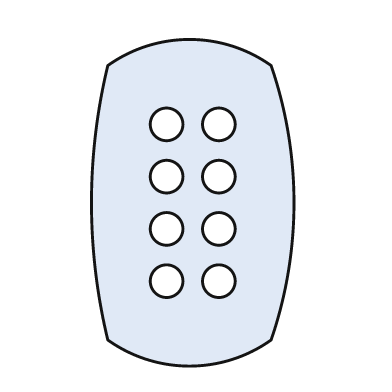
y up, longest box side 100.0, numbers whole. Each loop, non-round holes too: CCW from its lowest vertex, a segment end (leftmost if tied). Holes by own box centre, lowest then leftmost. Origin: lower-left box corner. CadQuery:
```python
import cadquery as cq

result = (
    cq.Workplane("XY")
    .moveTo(5.0, 8.0)
    .threePointArc((30.0, 0.0), (55.0, 8.0))
    .threePointArc((62.0, 50.0), (55.0, 92.0))
    .threePointArc((30.0, 100.0), (5.0, 92.0))
    .threePointArc((0.0, 50.0), (5.0, 8.0))
    .close()
    .moveTo(23.0, 26.0)
    .circle(5.0)
    .moveTo(39.0, 26.0)
    .circle(5.0)
    .moveTo(23.0, 42.0)
    .circle(5.0)
    .moveTo(39.0, 42.0)
    .circle(5.0)
    .moveTo(23.0, 58.0)
    .circle(5.0)
    .moveTo(39.0, 58.0)
    .circle(5.0)
    .moveTo(23.0, 74.0)
    .circle(5.0)
    .moveTo(39.0, 74.0)
    .circle(5.0)
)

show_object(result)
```